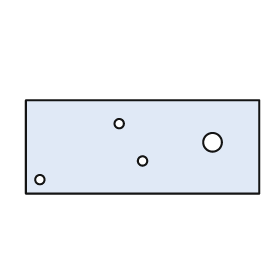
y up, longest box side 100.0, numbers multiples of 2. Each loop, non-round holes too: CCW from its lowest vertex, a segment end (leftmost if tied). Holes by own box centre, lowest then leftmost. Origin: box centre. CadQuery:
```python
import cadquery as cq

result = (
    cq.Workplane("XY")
    .moveTo(-50.0, -20.0)
    .lineTo(50.0, -20.0)
    .lineTo(50.0, 20.0)
    .lineTo(-50.0, 20.0)
    .close()
    .moveTo(-44.0, -14.0)
    .circle(2.0)
    .moveTo(0.0, -6.0)
    .circle(2.0)
    .moveTo(30.0, 2.0)
    .circle(4.0)
    .moveTo(-10.0, 10.0)
    .circle(2.0)
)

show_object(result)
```